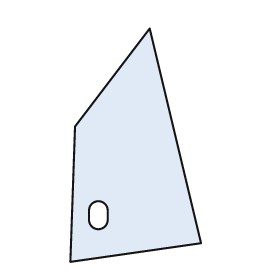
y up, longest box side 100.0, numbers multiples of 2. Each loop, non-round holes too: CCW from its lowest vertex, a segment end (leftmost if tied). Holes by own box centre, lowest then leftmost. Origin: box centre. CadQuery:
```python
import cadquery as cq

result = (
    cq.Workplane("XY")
    .moveTo(-28.0, -50.0)
    .lineTo(28.0, -42.0)
    .lineTo(6.0, 50.0)
    .lineTo(-26.0, 8.0)
    .close()
    .moveTo(-20.0, -32.0)
    .threePointArc((-16.0, -36.0), (-12.0, -32.0))
    .lineTo(-12.0, -28.0)
    .threePointArc((-16.0, -24.0), (-20.0, -28.0))
    .close()
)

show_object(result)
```